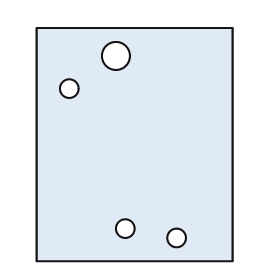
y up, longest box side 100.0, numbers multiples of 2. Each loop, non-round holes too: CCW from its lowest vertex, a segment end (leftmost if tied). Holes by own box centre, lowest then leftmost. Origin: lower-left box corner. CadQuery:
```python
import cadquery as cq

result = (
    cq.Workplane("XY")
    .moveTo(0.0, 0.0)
    .lineTo(84.0, 0.0)
    .lineTo(84.0, 100.0)
    .lineTo(0.0, 100.0)
    .close()
    .moveTo(60.0, 10.0)
    .circle(4.0)
    .moveTo(38.0, 14.0)
    .circle(4.0)
    .moveTo(14.0, 74.0)
    .circle(4.0)
    .moveTo(34.0, 88.0)
    .circle(6.0)
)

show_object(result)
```